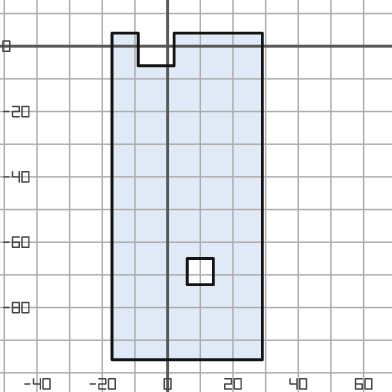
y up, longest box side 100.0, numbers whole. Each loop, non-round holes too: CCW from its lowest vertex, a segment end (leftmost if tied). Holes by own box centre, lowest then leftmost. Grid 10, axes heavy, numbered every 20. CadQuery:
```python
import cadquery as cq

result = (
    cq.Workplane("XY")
    .moveTo(-17.0, -96.0)
    .lineTo(29.0, -96.0)
    .lineTo(29.0, 4.0)
    .lineTo(2.0, 4.0)
    .lineTo(2.0, -6.0)
    .lineTo(-9.0, -6.0)
    .lineTo(-9.0, 4.0)
    .lineTo(-17.0, 4.0)
    .close()
    .moveTo(6.0, -73.0)
    .lineTo(14.0, -73.0)
    .lineTo(14.0, -65.0)
    .lineTo(6.0, -65.0)
    .close()
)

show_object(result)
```